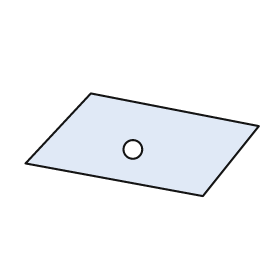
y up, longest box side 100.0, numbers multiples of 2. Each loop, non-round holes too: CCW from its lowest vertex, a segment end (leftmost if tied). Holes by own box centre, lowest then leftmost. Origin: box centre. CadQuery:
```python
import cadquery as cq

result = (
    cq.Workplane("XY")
    .moveTo(26.0, -22.0)
    .lineTo(50.0, 8.0)
    .lineTo(-22.0, 22.0)
    .lineTo(-50.0, -8.0)
    .close()
    .moveTo(-4.0, -2.0)
    .circle(4.0)
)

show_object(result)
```